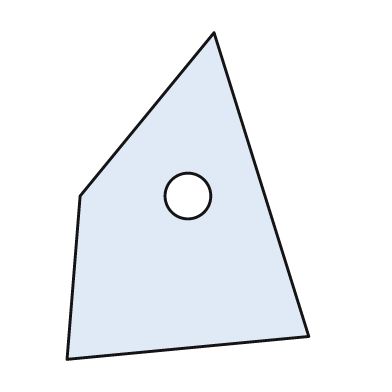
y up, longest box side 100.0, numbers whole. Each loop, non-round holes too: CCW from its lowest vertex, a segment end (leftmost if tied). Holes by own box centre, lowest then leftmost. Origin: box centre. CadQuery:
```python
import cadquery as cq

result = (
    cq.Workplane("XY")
    .moveTo(-37.0, -50.0)
    .lineTo(37.0, -43.0)
    .lineTo(8.0, 50.0)
    .lineTo(-33.0, 0.0)
    .close()
    .moveTo(0.0, 0.0)
    .circle(7.0)
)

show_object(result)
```